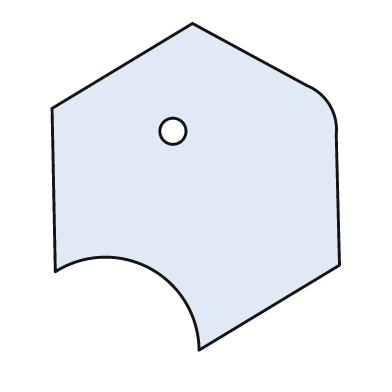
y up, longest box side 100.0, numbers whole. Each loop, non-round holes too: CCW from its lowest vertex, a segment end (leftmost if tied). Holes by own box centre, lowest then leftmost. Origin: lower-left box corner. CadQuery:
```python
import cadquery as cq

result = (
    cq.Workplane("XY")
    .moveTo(45.0, 0.0)
    .lineTo(88.0, 26.0)
    .lineTo(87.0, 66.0)
    .threePointArc((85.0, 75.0), (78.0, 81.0))
    .lineTo(43.0, 100.0)
    .lineTo(0.0, 74.0)
    .lineTo(1.0, 24.0)
    .threePointArc((30.0, 25.0), (45.0, 0.0))
    .close()
    .moveTo(37.0, 67.0)
    .circle(4.0)
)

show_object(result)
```